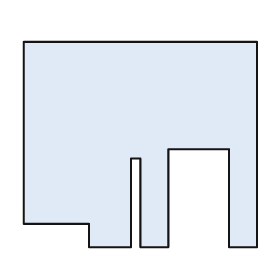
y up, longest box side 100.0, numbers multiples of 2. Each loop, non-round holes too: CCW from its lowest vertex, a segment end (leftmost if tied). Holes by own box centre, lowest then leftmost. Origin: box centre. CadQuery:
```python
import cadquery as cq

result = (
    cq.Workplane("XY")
    .moveTo(-22.0, -44.0)
    .lineTo(-4.0, -44.0)
    .lineTo(-4.0, -6.0)
    .lineTo(0.0, -6.0)
    .lineTo(0.0, -44.0)
    .lineTo(12.0, -44.0)
    .lineTo(12.0, -2.0)
    .lineTo(38.0, -2.0)
    .lineTo(38.0, -44.0)
    .lineTo(50.0, -44.0)
    .lineTo(50.0, 44.0)
    .lineTo(-50.0, 44.0)
    .lineTo(-50.0, -34.0)
    .lineTo(-22.0, -34.0)
    .close()
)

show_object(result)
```